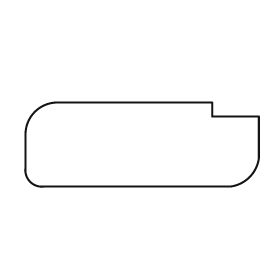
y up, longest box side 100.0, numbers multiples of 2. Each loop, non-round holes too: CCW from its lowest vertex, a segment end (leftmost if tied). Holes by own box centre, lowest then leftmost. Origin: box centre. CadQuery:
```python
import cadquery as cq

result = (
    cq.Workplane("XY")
    .moveTo(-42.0, -18.0)
    .lineTo(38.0, -18.0)
    .threePointArc((46.0, -14.0), (50.0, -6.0))
    .lineTo(50.0, 12.0)
    .lineTo(30.0, 12.0)
    .lineTo(30.0, 18.0)
    .lineTo(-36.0, 18.0)
    .threePointArc((-46.0, 14.0), (-50.0, 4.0))
    .lineTo(-50.0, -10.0)
    .threePointArc((-48.0, -16.0), (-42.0, -18.0))
    .close()
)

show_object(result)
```